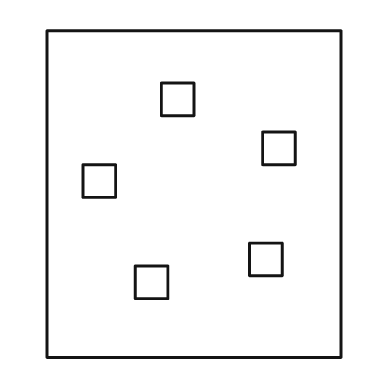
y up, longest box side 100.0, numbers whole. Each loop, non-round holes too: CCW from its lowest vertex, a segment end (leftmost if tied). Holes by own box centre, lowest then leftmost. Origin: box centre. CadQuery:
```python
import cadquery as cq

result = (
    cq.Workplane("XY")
    .moveTo(-45.0, -50.0)
    .lineTo(45.0, -50.0)
    .lineTo(45.0, 50.0)
    .lineTo(-45.0, 50.0)
    .close()
    .moveTo(-18.0, -32.0)
    .lineTo(-8.0, -32.0)
    .lineTo(-8.0, -22.0)
    .lineTo(-18.0, -22.0)
    .close()
    .moveTo(17.0, -25.0)
    .lineTo(27.0, -25.0)
    .lineTo(27.0, -15.0)
    .lineTo(17.0, -15.0)
    .close()
    .moveTo(-34.0, -1.0)
    .lineTo(-24.0, -1.0)
    .lineTo(-24.0, 9.0)
    .lineTo(-34.0, 9.0)
    .close()
    .moveTo(21.0, 9.0)
    .lineTo(31.0, 9.0)
    .lineTo(31.0, 19.0)
    .lineTo(21.0, 19.0)
    .close()
    .moveTo(-10.0, 24.0)
    .lineTo(0.0, 24.0)
    .lineTo(0.0, 34.0)
    .lineTo(-10.0, 34.0)
    .close()
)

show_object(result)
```